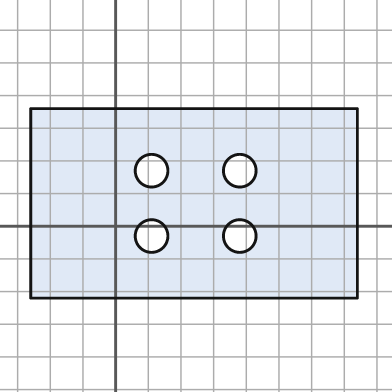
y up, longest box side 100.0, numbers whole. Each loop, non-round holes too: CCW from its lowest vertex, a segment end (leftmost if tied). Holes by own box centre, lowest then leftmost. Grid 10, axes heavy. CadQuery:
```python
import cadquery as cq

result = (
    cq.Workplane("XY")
    .moveTo(-26.0, -22.0)
    .lineTo(74.0, -22.0)
    .lineTo(74.0, 36.0)
    .lineTo(-26.0, 36.0)
    .close()
    .moveTo(11.0, -3.0)
    .circle(5.0)
    .moveTo(38.0, -3.0)
    .circle(5.0)
    .moveTo(11.0, 17.0)
    .circle(5.0)
    .moveTo(38.0, 17.0)
    .circle(5.0)
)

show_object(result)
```